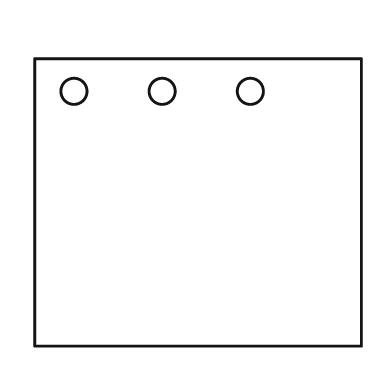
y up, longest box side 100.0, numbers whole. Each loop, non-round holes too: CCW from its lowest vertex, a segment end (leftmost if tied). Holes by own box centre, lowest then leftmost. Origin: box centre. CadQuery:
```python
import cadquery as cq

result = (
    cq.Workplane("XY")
    .moveTo(-50.0, -44.0)
    .lineTo(50.0, -44.0)
    .lineTo(50.0, 44.0)
    .lineTo(-50.0, 44.0)
    .close()
    .moveTo(-38.0, 34.0)
    .circle(4.0)
    .moveTo(-11.0, 34.0)
    .circle(4.0)
    .moveTo(16.0, 34.0)
    .circle(4.0)
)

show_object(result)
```